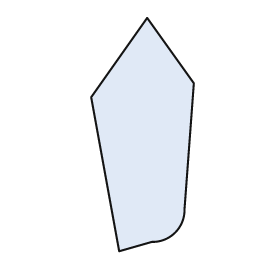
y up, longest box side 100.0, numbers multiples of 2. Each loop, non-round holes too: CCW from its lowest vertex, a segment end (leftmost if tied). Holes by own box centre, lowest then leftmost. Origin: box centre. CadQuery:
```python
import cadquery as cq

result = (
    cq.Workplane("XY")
    .moveTo(-10.0, -50.0)
    .lineTo(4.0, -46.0)
    .threePointArc((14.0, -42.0), (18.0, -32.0))
    .lineTo(22.0, 22.0)
    .lineTo(2.0, 50.0)
    .lineTo(-22.0, 16.0)
    .close()
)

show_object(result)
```